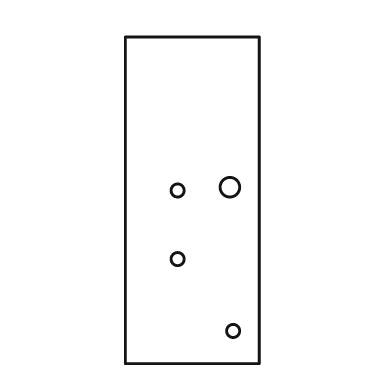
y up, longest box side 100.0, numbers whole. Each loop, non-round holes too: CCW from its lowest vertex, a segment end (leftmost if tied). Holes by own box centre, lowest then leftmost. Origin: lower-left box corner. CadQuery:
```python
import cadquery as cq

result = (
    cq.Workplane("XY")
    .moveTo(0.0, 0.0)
    .lineTo(41.0, 0.0)
    .lineTo(41.0, 100.0)
    .lineTo(0.0, 100.0)
    .close()
    .moveTo(33.0, 10.0)
    .circle(2.0)
    .moveTo(16.0, 32.0)
    .circle(2.0)
    .moveTo(16.0, 53.0)
    .circle(2.0)
    .moveTo(32.0, 54.0)
    .circle(3.0)
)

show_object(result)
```